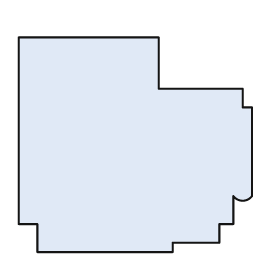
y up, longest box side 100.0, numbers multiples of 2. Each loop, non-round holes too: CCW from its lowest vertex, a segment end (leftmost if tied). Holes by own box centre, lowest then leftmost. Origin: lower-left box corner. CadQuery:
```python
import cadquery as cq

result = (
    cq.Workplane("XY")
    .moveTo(8.0, 0.0)
    .lineTo(66.0, 0.0)
    .lineTo(66.0, 4.0)
    .lineTo(86.0, 4.0)
    .lineTo(86.0, 12.0)
    .lineTo(92.0, 12.0)
    .lineTo(92.0, 24.0)
    .threePointArc((96.0, 22.0), (100.0, 24.0))
    .lineTo(100.0, 62.0)
    .lineTo(96.0, 62.0)
    .lineTo(96.0, 70.0)
    .lineTo(60.0, 70.0)
    .lineTo(60.0, 92.0)
    .lineTo(0.0, 92.0)
    .lineTo(0.0, 12.0)
    .lineTo(8.0, 12.0)
    .close()
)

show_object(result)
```